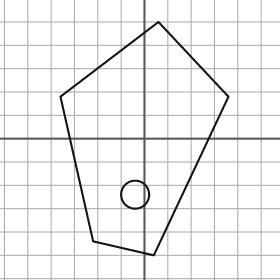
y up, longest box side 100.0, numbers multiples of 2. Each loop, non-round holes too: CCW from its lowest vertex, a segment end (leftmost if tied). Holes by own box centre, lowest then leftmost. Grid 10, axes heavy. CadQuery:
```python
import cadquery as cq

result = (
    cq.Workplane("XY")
    .moveTo(4.0, -50.0)
    .lineTo(36.0, 18.0)
    .lineTo(6.0, 50.0)
    .lineTo(-36.0, 18.0)
    .lineTo(-22.0, -44.0)
    .close()
    .moveTo(-4.0, -24.0)
    .circle(6.0)
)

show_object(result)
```